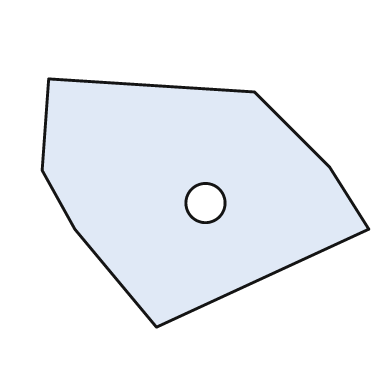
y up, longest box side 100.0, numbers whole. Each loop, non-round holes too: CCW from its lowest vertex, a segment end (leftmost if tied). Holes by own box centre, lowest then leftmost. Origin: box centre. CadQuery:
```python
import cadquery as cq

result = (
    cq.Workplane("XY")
    .moveTo(-15.0, -38.0)
    .lineTo(50.0, -8.0)
    .lineTo(38.0, 11.0)
    .lineTo(15.0, 34.0)
    .lineTo(-48.0, 38.0)
    .lineTo(-50.0, 10.0)
    .lineTo(-40.0, -8.0)
    .close()
    .moveTo(0.0, 0.0)
    .circle(6.0)
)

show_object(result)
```